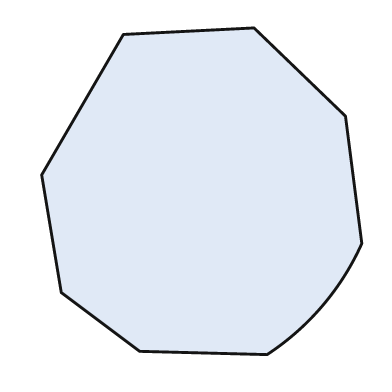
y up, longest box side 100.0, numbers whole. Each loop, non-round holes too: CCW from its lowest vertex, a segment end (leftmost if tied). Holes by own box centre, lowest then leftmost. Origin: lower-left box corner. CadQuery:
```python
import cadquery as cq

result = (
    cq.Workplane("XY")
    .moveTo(69.0, 0.0)
    .threePointArc((86.0, 15.0), (98.0, 34.0))
    .lineTo(93.0, 73.0)
    .lineTo(65.0, 100.0)
    .lineTo(25.0, 98.0)
    .lineTo(0.0, 55.0)
    .lineTo(6.0, 19.0)
    .lineTo(30.0, 1.0)
    .close()
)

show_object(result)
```